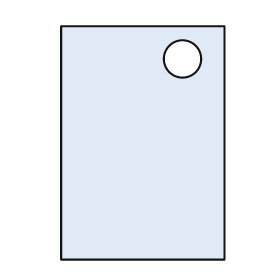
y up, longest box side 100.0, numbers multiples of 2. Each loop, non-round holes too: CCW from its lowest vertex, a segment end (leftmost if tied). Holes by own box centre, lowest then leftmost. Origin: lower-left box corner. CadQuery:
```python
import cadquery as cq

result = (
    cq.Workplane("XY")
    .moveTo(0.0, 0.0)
    .lineTo(70.0, 0.0)
    .lineTo(70.0, 100.0)
    .lineTo(0.0, 100.0)
    .close()
    .moveTo(52.0, 86.0)
    .circle(8.0)
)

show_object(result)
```